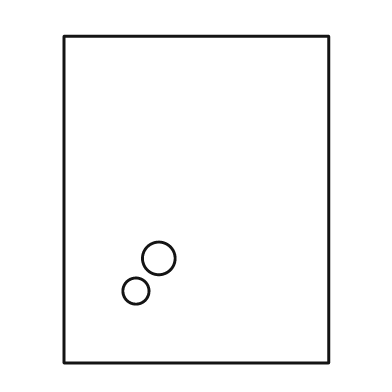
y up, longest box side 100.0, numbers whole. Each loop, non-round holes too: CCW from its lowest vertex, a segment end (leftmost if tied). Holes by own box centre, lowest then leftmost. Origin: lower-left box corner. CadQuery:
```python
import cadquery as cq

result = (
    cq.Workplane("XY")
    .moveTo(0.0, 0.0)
    .lineTo(81.0, 0.0)
    .lineTo(81.0, 100.0)
    .lineTo(0.0, 100.0)
    .close()
    .moveTo(22.0, 22.0)
    .circle(4.0)
    .moveTo(29.0, 32.0)
    .circle(5.0)
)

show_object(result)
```